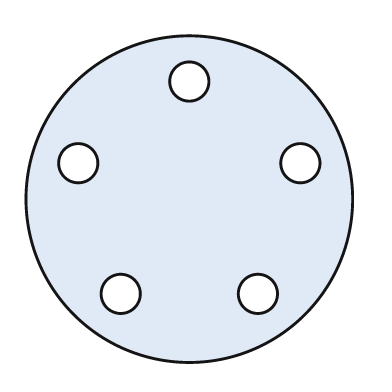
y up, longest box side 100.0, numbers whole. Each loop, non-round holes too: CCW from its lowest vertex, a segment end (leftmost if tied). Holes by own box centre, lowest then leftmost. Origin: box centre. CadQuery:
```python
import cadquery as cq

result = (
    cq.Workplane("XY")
    .moveTo(0.0, 0.0)
    .circle(50.0)
    .moveTo(-21.0, -29.0)
    .circle(6.0)
    .moveTo(21.0, -29.0)
    .circle(6.0)
    .moveTo(-34.0, 11.0)
    .circle(6.0)
    .moveTo(34.0, 11.0)
    .circle(6.0)
    .moveTo(0.0, 36.0)
    .circle(6.0)
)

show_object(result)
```